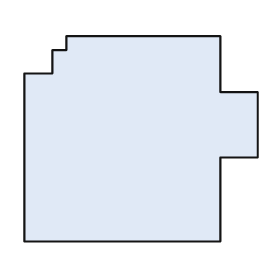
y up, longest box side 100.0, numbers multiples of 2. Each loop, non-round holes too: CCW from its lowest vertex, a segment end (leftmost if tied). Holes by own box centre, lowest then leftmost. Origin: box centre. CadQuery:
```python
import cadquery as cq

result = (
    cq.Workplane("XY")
    .moveTo(-50.0, -44.0)
    .lineTo(34.0, -44.0)
    .lineTo(34.0, -8.0)
    .lineTo(50.0, -8.0)
    .lineTo(50.0, 20.0)
    .lineTo(34.0, 20.0)
    .lineTo(34.0, 44.0)
    .lineTo(-32.0, 44.0)
    .lineTo(-32.0, 38.0)
    .lineTo(-38.0, 38.0)
    .lineTo(-38.0, 28.0)
    .lineTo(-50.0, 28.0)
    .close()
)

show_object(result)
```